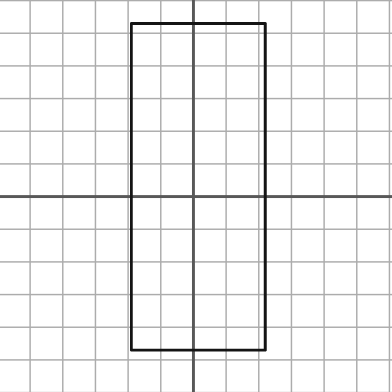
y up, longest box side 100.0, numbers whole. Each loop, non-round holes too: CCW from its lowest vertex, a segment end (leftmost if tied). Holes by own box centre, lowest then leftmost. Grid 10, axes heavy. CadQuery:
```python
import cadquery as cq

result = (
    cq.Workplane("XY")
    .moveTo(-19.0, -47.0)
    .lineTo(22.0, -47.0)
    .lineTo(22.0, 53.0)
    .lineTo(-19.0, 53.0)
    .close()
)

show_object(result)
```